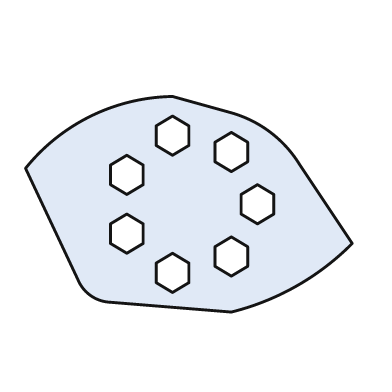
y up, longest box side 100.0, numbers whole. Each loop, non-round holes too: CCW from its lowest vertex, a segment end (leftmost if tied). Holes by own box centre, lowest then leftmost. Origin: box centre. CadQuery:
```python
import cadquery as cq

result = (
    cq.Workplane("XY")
    .moveTo(13.0, -33.0)
    .threePointArc((33.0, -25.0), (50.0, -12.0))
    .lineTo(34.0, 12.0)
    .threePointArc((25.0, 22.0), (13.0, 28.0))
    .lineTo(-5.0, 33.0)
    .threePointArc((-30.0, 27.0), (-50.0, 11.0))
    .lineTo(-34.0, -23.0)
    .threePointArc((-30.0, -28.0), (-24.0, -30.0))
    .close()
    .moveTo(-5.0, -27.0)
    .lineTo(0.0, -24.0)
    .lineTo(0.0, -18.0)
    .lineTo(-5.0, -15.0)
    .lineTo(-10.0, -18.0)
    .lineTo(-10.0, -24.0)
    .close()
    .moveTo(13.0, -22.0)
    .lineTo(18.0, -19.0)
    .lineTo(18.0, -13.0)
    .lineTo(13.0, -10.0)
    .lineTo(8.0, -13.0)
    .lineTo(8.0, -19.0)
    .close()
    .moveTo(-19.0, -15.0)
    .lineTo(-14.0, -12.0)
    .lineTo(-14.0, -6.0)
    .lineTo(-19.0, -3.0)
    .lineTo(-24.0, -6.0)
    .lineTo(-24.0, -12.0)
    .close()
    .moveTo(21.0, -6.0)
    .lineTo(26.0, -3.0)
    .lineTo(26.0, 3.0)
    .lineTo(21.0, 6.0)
    .lineTo(16.0, 3.0)
    .lineTo(16.0, -3.0)
    .close()
    .moveTo(-19.0, 3.0)
    .lineTo(-14.0, 6.0)
    .lineTo(-14.0, 12.0)
    .lineTo(-19.0, 15.0)
    .lineTo(-24.0, 12.0)
    .lineTo(-24.0, 6.0)
    .close()
    .moveTo(13.0, 10.0)
    .lineTo(18.0, 13.0)
    .lineTo(18.0, 19.0)
    .lineTo(13.0, 22.0)
    .lineTo(8.0, 19.0)
    .lineTo(8.0, 13.0)
    .close()
    .moveTo(-5.0, 15.0)
    .lineTo(0.0, 18.0)
    .lineTo(0.0, 24.0)
    .lineTo(-5.0, 27.0)
    .lineTo(-10.0, 24.0)
    .lineTo(-10.0, 18.0)
    .close()
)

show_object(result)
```